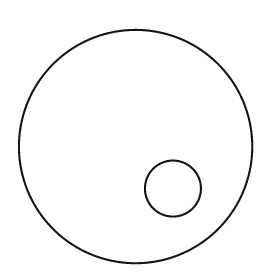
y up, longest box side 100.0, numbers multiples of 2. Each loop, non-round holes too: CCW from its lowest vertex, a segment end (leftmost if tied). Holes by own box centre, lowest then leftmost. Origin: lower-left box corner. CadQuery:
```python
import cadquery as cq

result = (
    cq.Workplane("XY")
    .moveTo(50.0, 50.0)
    .circle(50.0)
    .moveTo(66.0, 32.0)
    .circle(12.0)
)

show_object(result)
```